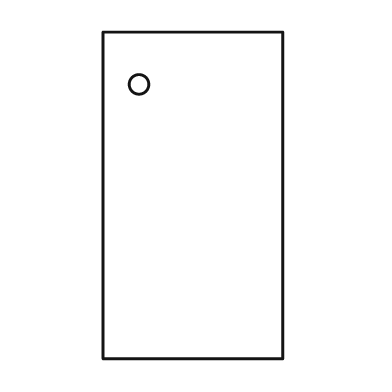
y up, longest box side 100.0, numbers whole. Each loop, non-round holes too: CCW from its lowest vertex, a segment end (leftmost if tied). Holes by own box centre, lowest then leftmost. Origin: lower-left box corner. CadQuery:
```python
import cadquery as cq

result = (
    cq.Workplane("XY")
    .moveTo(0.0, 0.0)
    .lineTo(55.0, 0.0)
    .lineTo(55.0, 100.0)
    .lineTo(0.0, 100.0)
    .close()
    .moveTo(11.0, 84.0)
    .circle(3.0)
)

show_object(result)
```